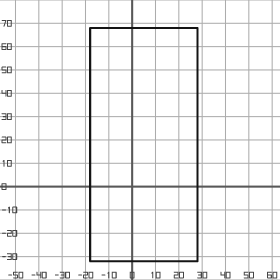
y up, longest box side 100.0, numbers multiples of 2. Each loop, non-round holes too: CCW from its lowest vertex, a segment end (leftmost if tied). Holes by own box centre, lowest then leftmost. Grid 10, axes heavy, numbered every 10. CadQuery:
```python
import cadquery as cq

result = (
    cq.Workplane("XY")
    .moveTo(-18.0, -32.0)
    .lineTo(28.0, -32.0)
    .lineTo(28.0, 68.0)
    .lineTo(-18.0, 68.0)
    .close()
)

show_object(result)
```